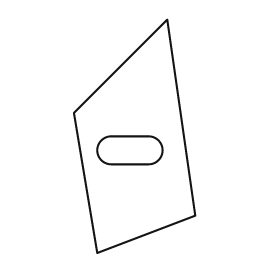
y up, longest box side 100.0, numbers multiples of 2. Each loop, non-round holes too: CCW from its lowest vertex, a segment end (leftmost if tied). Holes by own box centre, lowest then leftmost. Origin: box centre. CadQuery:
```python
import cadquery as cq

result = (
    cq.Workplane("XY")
    .moveTo(-16.0, -50.0)
    .lineTo(26.0, -34.0)
    .lineTo(14.0, 50.0)
    .lineTo(-26.0, 10.0)
    .close()
    .moveTo(-10.0, -12.0)
    .lineTo(6.0, -12.0)
    .threePointArc((12.0, -6.0), (6.0, 0.0))
    .lineTo(-10.0, 0.0)
    .threePointArc((-16.0, -6.0), (-10.0, -12.0))
    .close()
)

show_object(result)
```